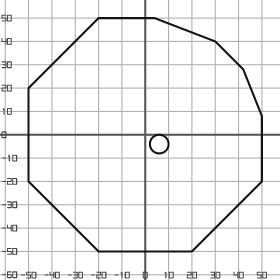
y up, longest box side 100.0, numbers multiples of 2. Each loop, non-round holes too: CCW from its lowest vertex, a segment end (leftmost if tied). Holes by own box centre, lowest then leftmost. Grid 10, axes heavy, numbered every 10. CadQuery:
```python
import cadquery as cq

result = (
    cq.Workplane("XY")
    .moveTo(-20.0, -50.0)
    .lineTo(20.0, -50.0)
    .lineTo(50.0, -20.0)
    .lineTo(50.0, 8.0)
    .lineTo(42.0, 28.0)
    .lineTo(30.0, 40.0)
    .lineTo(4.0, 50.0)
    .lineTo(-20.0, 50.0)
    .lineTo(-50.0, 20.0)
    .lineTo(-50.0, -20.0)
    .close()
    .moveTo(6.0, -4.0)
    .circle(4.0)
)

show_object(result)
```